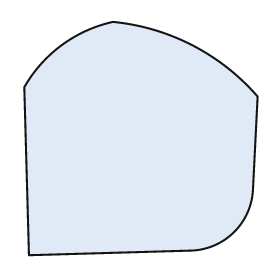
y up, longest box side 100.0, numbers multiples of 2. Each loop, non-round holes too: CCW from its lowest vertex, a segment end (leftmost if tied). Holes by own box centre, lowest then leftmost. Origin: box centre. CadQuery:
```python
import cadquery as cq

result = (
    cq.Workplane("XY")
    .moveTo(-48.0, -50.0)
    .lineTo(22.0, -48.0)
    .threePointArc((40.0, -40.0), (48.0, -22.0))
    .lineTo(50.0, 18.0)
    .threePointArc((22.0, 40.0), (-12.0, 50.0))
    .threePointArc((-34.0, 40.0), (-50.0, 22.0))
    .close()
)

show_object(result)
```